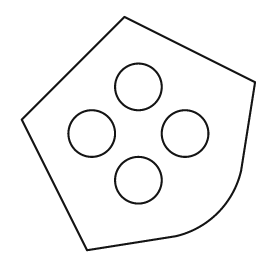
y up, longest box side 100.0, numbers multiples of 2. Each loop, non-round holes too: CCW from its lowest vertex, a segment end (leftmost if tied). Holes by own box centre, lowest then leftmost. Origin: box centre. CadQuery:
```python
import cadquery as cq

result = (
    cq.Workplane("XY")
    .moveTo(-22.0, -50.0)
    .lineTo(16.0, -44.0)
    .threePointArc((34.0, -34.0), (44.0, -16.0))
    .lineTo(50.0, 22.0)
    .lineTo(-6.0, 50.0)
    .lineTo(-50.0, 6.0)
    .close()
    .moveTo(0.0, -20.0)
    .circle(10.0)
    .moveTo(-20.0, 0.0)
    .circle(10.0)
    .moveTo(20.0, 0.0)
    .circle(10.0)
    .moveTo(0.0, 20.0)
    .circle(10.0)
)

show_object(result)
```